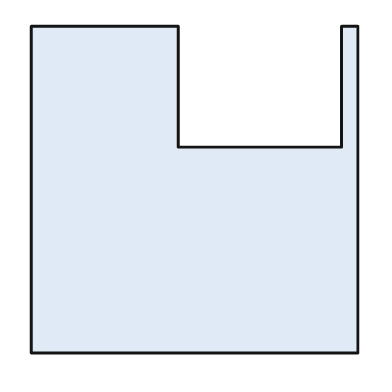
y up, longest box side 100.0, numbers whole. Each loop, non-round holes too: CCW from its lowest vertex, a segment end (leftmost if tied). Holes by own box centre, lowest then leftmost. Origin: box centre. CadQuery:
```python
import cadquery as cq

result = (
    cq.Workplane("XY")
    .moveTo(-50.0, -50.0)
    .lineTo(50.0, -50.0)
    .lineTo(50.0, 50.0)
    .lineTo(45.0, 50.0)
    .lineTo(45.0, 13.0)
    .lineTo(-5.0, 13.0)
    .lineTo(-5.0, 50.0)
    .lineTo(-50.0, 50.0)
    .close()
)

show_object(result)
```